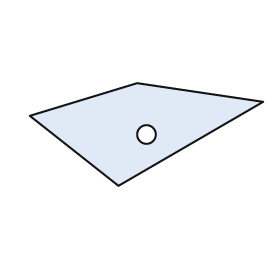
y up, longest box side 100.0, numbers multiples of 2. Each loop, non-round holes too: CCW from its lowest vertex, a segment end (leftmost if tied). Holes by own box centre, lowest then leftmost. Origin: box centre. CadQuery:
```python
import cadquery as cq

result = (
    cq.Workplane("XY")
    .moveTo(-12.0, -22.0)
    .lineTo(50.0, 14.0)
    .lineTo(-4.0, 22.0)
    .lineTo(-50.0, 8.0)
    .close()
    .moveTo(0.0, 0.0)
    .circle(4.0)
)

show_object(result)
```